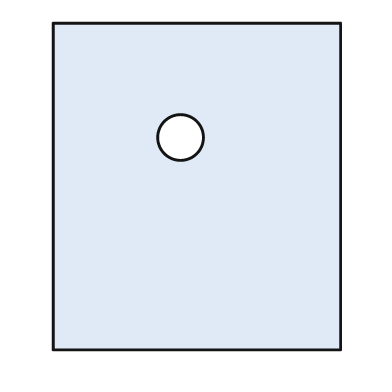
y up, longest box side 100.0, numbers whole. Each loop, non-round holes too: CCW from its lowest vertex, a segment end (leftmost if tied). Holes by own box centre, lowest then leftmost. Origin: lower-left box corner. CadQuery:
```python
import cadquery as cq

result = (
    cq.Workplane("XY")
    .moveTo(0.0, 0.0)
    .lineTo(88.0, 0.0)
    .lineTo(88.0, 100.0)
    .lineTo(0.0, 100.0)
    .close()
    .moveTo(39.0, 65.0)
    .circle(7.0)
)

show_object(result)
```